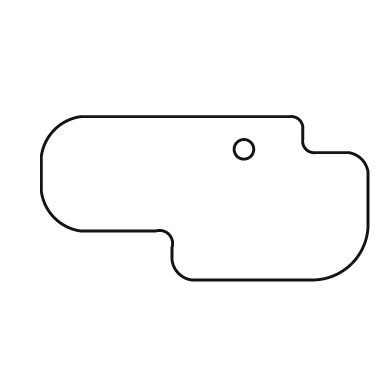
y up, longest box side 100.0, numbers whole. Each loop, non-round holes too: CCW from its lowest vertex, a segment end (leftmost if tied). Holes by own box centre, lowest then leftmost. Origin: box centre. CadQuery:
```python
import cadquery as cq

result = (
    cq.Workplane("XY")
    .moveTo(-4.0, -25.0)
    .lineTo(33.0, -25.0)
    .threePointArc((45.0, -20.0), (50.0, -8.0))
    .lineTo(50.0, 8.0)
    .threePointArc((48.0, 12.0), (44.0, 14.0))
    .lineTo(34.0, 14.0)
    .threePointArc((31.0, 15.0), (30.0, 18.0))
    .lineTo(30.0, 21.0)
    .threePointArc((29.0, 24.0), (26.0, 25.0))
    .lineTo(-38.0, 25.0)
    .threePointArc((-46.0, 21.0), (-50.0, 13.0))
    .lineTo(-50.0, 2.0)
    .threePointArc((-46.0, -6.0), (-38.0, -10.0))
    .lineTo(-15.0, -10.0)
    .threePointArc((-11.0, -11.0), (-10.0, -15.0))
    .lineTo(-10.0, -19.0)
    .threePointArc((-8.0, -23.0), (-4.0, -25.0))
    .close()
    .moveTo(12.0, 15.0)
    .circle(3.0)
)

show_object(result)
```